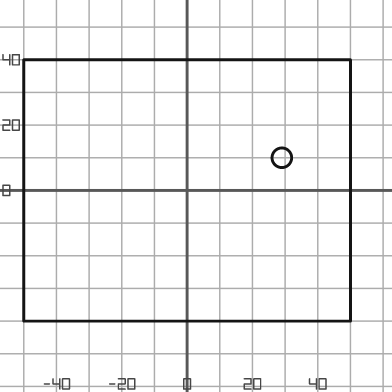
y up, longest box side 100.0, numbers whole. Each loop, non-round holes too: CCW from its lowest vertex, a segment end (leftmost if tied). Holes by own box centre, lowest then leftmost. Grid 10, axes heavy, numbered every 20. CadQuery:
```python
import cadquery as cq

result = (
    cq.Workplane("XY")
    .moveTo(-50.0, -40.0)
    .lineTo(50.0, -40.0)
    .lineTo(50.0, 40.0)
    .lineTo(-50.0, 40.0)
    .close()
    .moveTo(29.0, 10.0)
    .circle(3.0)
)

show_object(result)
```